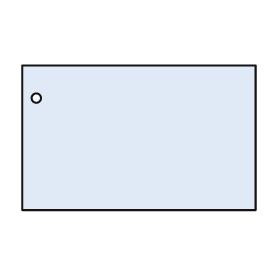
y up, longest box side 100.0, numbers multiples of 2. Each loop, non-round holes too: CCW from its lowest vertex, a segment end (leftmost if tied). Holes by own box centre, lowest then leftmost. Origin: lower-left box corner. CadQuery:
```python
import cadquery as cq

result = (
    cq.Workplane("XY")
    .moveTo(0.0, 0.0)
    .lineTo(100.0, 0.0)
    .lineTo(100.0, 62.0)
    .lineTo(0.0, 62.0)
    .close()
    .moveTo(6.0, 48.0)
    .circle(2.0)
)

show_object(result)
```